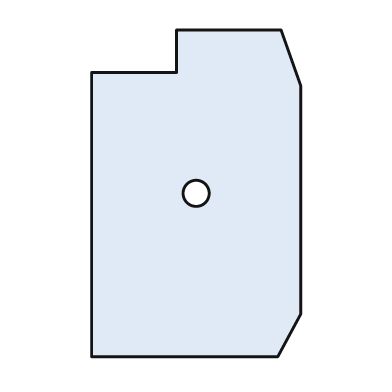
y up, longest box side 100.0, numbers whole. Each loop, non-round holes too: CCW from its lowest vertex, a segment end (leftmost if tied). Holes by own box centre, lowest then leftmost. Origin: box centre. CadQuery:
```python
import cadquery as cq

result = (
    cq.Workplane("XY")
    .moveTo(-32.0, -50.0)
    .lineTo(25.0, -50.0)
    .lineTo(32.0, -37.0)
    .lineTo(32.0, 33.0)
    .lineTo(26.0, 50.0)
    .lineTo(-6.0, 50.0)
    .lineTo(-6.0, 37.0)
    .lineTo(-32.0, 37.0)
    .close()
    .moveTo(0.0, 0.0)
    .circle(4.0)
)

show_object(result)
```